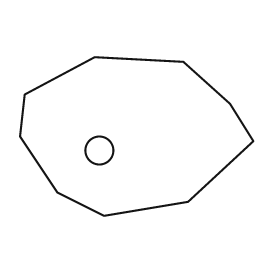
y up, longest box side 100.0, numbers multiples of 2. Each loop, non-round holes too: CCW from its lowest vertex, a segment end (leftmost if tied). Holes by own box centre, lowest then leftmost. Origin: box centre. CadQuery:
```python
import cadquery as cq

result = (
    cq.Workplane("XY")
    .moveTo(-14.0, -34.0)
    .lineTo(22.0, -28.0)
    .lineTo(50.0, -2.0)
    .lineTo(40.0, 14.0)
    .lineTo(20.0, 32.0)
    .lineTo(-18.0, 34.0)
    .lineTo(-48.0, 18.0)
    .lineTo(-50.0, 0.0)
    .lineTo(-34.0, -24.0)
    .close()
    .moveTo(-16.0, -6.0)
    .circle(6.0)
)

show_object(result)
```